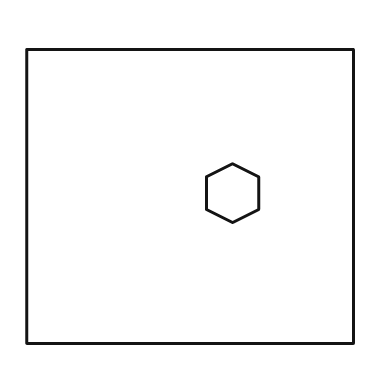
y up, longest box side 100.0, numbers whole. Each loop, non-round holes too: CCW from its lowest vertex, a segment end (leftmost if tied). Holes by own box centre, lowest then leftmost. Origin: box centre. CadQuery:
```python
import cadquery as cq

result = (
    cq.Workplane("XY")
    .moveTo(-50.0, -45.0)
    .lineTo(50.0, -45.0)
    .lineTo(50.0, 45.0)
    .lineTo(-50.0, 45.0)
    .close()
    .moveTo(13.0, -8.0)
    .lineTo(21.0, -4.0)
    .lineTo(21.0, 6.0)
    .lineTo(13.0, 10.0)
    .lineTo(5.0, 6.0)
    .lineTo(5.0, -4.0)
    .close()
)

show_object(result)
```